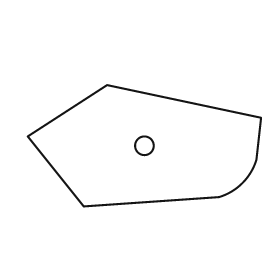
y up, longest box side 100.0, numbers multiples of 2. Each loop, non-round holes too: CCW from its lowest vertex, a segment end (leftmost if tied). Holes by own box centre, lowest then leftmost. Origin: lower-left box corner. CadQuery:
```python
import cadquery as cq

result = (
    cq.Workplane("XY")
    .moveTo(24.0, 0.0)
    .lineTo(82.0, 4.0)
    .threePointArc((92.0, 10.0), (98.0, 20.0))
    .lineTo(100.0, 38.0)
    .lineTo(34.0, 52.0)
    .lineTo(0.0, 30.0)
    .close()
    .moveTo(50.0, 26.0)
    .circle(4.0)
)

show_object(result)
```